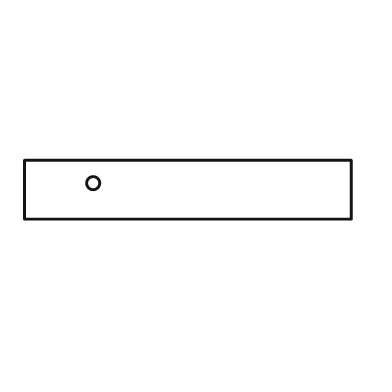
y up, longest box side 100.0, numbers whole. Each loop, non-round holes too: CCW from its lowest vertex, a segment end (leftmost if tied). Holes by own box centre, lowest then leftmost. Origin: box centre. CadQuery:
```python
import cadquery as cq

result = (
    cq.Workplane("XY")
    .moveTo(-50.0, -9.0)
    .lineTo(50.0, -9.0)
    .lineTo(50.0, 9.0)
    .lineTo(-50.0, 9.0)
    .close()
    .moveTo(-29.0, 2.0)
    .circle(2.0)
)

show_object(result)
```